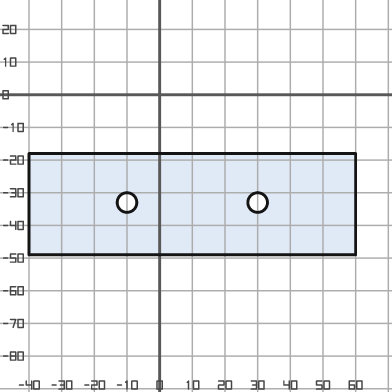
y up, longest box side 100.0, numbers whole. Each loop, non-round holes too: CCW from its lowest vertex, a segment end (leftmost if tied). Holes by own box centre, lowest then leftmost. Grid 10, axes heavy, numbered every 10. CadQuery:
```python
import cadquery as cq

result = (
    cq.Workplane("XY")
    .moveTo(-40.0, -49.0)
    .lineTo(60.0, -49.0)
    .lineTo(60.0, -18.0)
    .lineTo(-40.0, -18.0)
    .close()
    .moveTo(-10.0, -33.0)
    .circle(3.0)
    .moveTo(30.0, -33.0)
    .circle(3.0)
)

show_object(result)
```